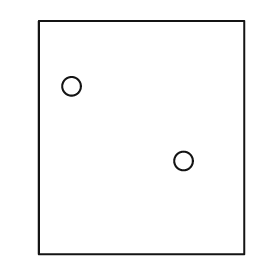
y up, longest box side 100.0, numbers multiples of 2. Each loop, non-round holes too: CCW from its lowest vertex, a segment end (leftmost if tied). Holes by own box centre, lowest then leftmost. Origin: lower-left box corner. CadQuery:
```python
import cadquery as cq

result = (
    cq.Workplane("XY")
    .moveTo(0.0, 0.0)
    .lineTo(88.0, 0.0)
    .lineTo(88.0, 100.0)
    .lineTo(0.0, 100.0)
    .close()
    .moveTo(62.0, 40.0)
    .circle(4.0)
    .moveTo(14.0, 72.0)
    .circle(4.0)
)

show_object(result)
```